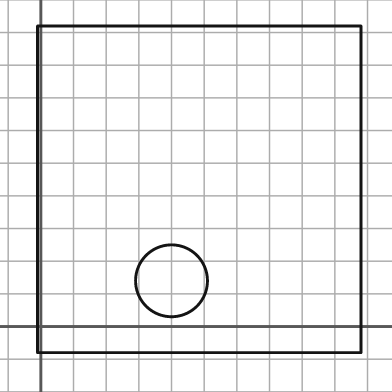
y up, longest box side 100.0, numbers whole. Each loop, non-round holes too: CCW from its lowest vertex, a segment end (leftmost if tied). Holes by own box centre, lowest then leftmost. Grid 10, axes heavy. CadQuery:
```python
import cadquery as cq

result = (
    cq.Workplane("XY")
    .moveTo(-1.0, -8.0)
    .lineTo(98.0, -8.0)
    .lineTo(98.0, 92.0)
    .lineTo(-1.0, 92.0)
    .close()
    .moveTo(40.0, 14.0)
    .circle(11.0)
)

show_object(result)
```